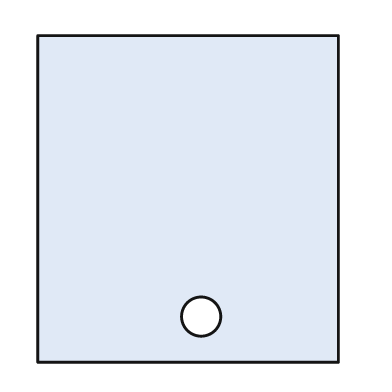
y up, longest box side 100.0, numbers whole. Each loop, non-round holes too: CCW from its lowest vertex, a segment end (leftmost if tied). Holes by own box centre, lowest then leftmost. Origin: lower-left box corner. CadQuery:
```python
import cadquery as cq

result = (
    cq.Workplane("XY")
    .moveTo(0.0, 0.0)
    .lineTo(92.0, 0.0)
    .lineTo(92.0, 100.0)
    .lineTo(0.0, 100.0)
    .close()
    .moveTo(50.0, 14.0)
    .circle(6.0)
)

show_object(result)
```